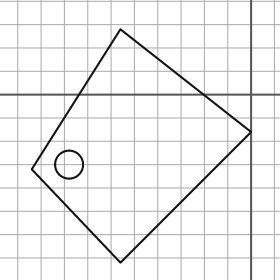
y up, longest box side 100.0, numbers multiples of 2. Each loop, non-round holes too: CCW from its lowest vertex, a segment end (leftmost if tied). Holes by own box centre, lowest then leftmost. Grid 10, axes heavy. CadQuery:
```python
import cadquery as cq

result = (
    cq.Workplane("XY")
    .moveTo(-56.0, -72.0)
    .lineTo(0.0, -16.0)
    .lineTo(-56.0, 28.0)
    .lineTo(-94.0, -32.0)
    .close()
    .moveTo(-78.0, -30.0)
    .circle(6.0)
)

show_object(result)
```